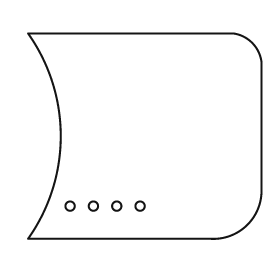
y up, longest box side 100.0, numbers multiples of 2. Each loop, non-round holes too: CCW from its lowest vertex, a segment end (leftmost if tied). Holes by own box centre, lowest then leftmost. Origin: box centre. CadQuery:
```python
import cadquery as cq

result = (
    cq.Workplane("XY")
    .moveTo(-50.0, -44.0)
    .lineTo(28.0, -44.0)
    .threePointArc((44.0, -38.0), (50.0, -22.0))
    .lineTo(50.0, 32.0)
    .threePointArc((46.0, 40.0), (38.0, 44.0))
    .lineTo(-50.0, 44.0)
    .threePointArc((-36.0, 0.0), (-50.0, -44.0))
    .close()
    .moveTo(-32.0, -30.0)
    .circle(2.0)
    .moveTo(-22.0, -30.0)
    .circle(2.0)
    .moveTo(-12.0, -30.0)
    .circle(2.0)
    .moveTo(-2.0, -30.0)
    .circle(2.0)
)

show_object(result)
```